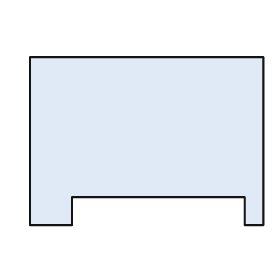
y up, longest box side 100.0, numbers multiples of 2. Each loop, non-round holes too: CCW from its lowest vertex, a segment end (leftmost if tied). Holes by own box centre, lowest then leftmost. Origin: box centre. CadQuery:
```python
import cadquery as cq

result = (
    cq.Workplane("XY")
    .moveTo(-50.0, -36.0)
    .lineTo(-32.0, -36.0)
    .lineTo(-32.0, -24.0)
    .lineTo(42.0, -24.0)
    .lineTo(42.0, -36.0)
    .lineTo(50.0, -36.0)
    .lineTo(50.0, 36.0)
    .lineTo(-50.0, 36.0)
    .close()
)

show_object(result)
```